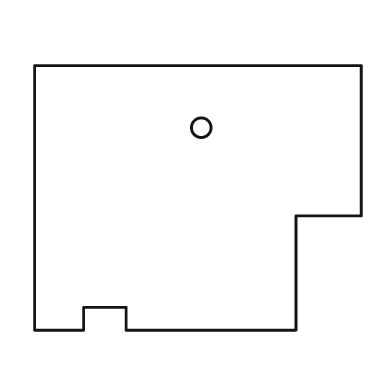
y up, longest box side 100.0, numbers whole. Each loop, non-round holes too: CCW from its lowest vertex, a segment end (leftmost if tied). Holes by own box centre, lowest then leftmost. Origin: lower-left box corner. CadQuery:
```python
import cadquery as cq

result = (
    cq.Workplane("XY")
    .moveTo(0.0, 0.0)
    .lineTo(15.0, 0.0)
    .lineTo(15.0, 7.0)
    .lineTo(28.0, 7.0)
    .lineTo(28.0, 0.0)
    .lineTo(80.0, 0.0)
    .lineTo(80.0, 35.0)
    .lineTo(100.0, 35.0)
    .lineTo(100.0, 81.0)
    .lineTo(0.0, 81.0)
    .close()
    .moveTo(51.0, 62.0)
    .circle(3.0)
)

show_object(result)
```